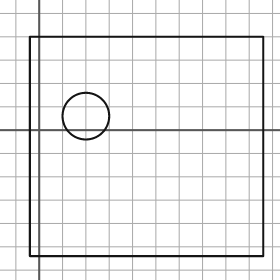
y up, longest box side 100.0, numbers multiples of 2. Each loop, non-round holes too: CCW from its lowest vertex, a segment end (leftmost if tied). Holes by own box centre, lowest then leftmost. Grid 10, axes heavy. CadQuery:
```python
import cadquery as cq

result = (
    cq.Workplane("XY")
    .moveTo(-4.0, -54.0)
    .lineTo(96.0, -54.0)
    .lineTo(96.0, 40.0)
    .lineTo(-4.0, 40.0)
    .close()
    .moveTo(20.0, 6.0)
    .circle(10.0)
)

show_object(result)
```